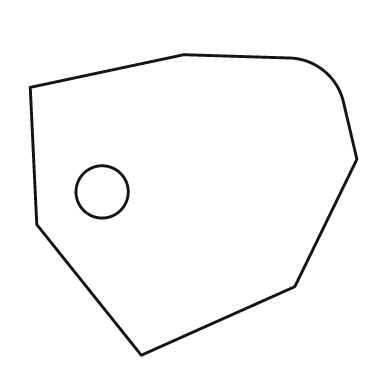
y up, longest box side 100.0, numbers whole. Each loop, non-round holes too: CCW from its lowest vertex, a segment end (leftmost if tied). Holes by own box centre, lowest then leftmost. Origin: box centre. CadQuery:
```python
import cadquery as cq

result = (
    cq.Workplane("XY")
    .moveTo(-16.0, -46.0)
    .lineTo(31.0, -25.0)
    .lineTo(50.0, 14.0)
    .lineTo(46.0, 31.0)
    .threePointArc((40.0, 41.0), (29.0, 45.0))
    .lineTo(-3.0, 46.0)
    .lineTo(-50.0, 36.0)
    .lineTo(-48.0, -6.0)
    .close()
    .moveTo(-28.0, 4.0)
    .circle(8.0)
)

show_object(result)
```